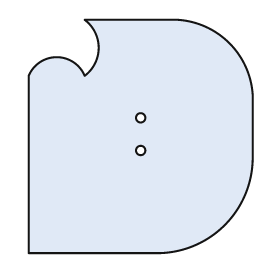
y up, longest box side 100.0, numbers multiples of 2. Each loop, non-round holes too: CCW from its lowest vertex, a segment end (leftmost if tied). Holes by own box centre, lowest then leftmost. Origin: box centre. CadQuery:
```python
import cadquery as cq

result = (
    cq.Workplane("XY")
    .moveTo(-48.0, -50.0)
    .lineTo(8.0, -50.0)
    .threePointArc((36.0, -38.0), (48.0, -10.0))
    .lineTo(48.0, 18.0)
    .threePointArc((38.0, 40.0), (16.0, 50.0))
    .lineTo(-24.0, 50.0)
    .threePointArc((-18.0, 38.0), (-24.0, 26.0))
    .threePointArc((-36.0, 34.0), (-48.0, 26.0))
    .close()
    .moveTo(0.0, -6.0)
    .circle(2.0)
    .moveTo(0.0, 8.0)
    .circle(2.0)
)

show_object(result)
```